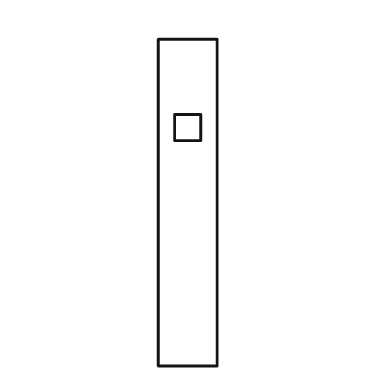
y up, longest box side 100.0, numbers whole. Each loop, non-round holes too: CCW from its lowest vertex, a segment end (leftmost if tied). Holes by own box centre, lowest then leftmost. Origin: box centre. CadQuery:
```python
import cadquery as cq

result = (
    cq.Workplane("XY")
    .moveTo(-9.0, -50.0)
    .lineTo(9.0, -50.0)
    .lineTo(9.0, 50.0)
    .lineTo(-9.0, 50.0)
    .close()
    .moveTo(-4.0, 19.0)
    .lineTo(4.0, 19.0)
    .lineTo(4.0, 27.0)
    .lineTo(-4.0, 27.0)
    .close()
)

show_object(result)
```